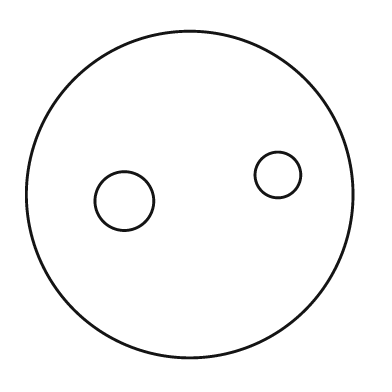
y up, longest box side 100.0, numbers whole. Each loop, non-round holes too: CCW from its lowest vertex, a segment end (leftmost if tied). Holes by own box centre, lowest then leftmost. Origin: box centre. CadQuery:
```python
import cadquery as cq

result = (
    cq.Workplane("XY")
    .moveTo(0.0, 0.0)
    .circle(50.0)
    .moveTo(-20.0, -2.0)
    .circle(9.0)
    .moveTo(27.0, 6.0)
    .circle(7.0)
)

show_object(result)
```